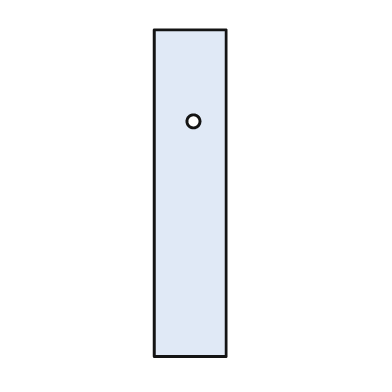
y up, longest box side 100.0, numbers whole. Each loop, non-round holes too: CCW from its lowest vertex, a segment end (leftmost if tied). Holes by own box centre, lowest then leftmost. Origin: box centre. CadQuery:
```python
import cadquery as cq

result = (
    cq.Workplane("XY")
    .moveTo(-11.0, -50.0)
    .lineTo(11.0, -50.0)
    .lineTo(11.0, 50.0)
    .lineTo(-11.0, 50.0)
    .close()
    .moveTo(1.0, 22.0)
    .circle(2.0)
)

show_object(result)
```